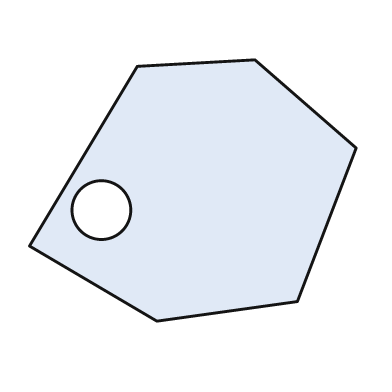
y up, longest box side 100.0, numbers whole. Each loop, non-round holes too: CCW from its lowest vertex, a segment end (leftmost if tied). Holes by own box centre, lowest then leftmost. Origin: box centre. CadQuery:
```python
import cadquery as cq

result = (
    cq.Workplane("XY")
    .moveTo(-11.0, -40.0)
    .lineTo(32.0, -34.0)
    .lineTo(50.0, 13.0)
    .lineTo(19.0, 40.0)
    .lineTo(-17.0, 38.0)
    .lineTo(-50.0, -17.0)
    .close()
    .moveTo(-28.0, -6.0)
    .circle(9.0)
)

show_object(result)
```